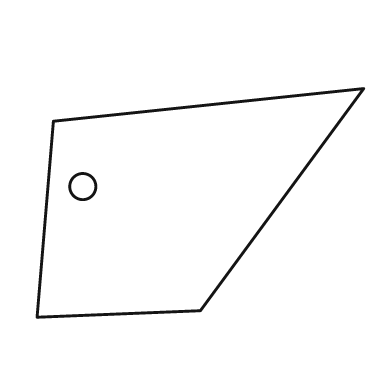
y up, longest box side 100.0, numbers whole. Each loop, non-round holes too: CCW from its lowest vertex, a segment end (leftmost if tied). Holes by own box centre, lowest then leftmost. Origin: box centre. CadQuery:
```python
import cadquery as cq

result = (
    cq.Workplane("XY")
    .moveTo(-50.0, -35.0)
    .lineTo(0.0, -33.0)
    .lineTo(50.0, 35.0)
    .lineTo(-45.0, 25.0)
    .close()
    .moveTo(-36.0, 5.0)
    .circle(4.0)
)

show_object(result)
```